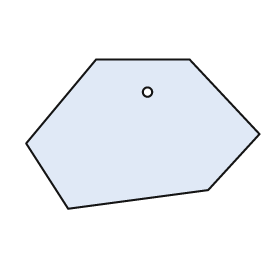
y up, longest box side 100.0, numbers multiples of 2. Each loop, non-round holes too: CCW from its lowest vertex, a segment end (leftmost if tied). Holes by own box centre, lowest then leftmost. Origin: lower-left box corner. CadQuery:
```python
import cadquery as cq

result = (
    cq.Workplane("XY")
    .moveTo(18.0, 0.0)
    .lineTo(78.0, 8.0)
    .lineTo(100.0, 32.0)
    .lineTo(70.0, 64.0)
    .lineTo(30.0, 64.0)
    .lineTo(0.0, 28.0)
    .close()
    .moveTo(52.0, 50.0)
    .circle(2.0)
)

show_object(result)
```